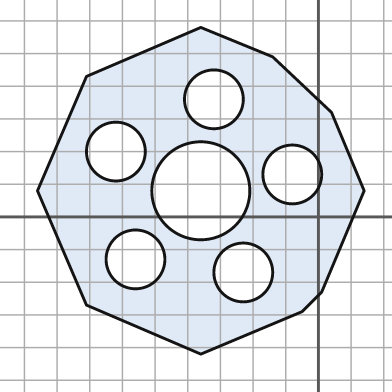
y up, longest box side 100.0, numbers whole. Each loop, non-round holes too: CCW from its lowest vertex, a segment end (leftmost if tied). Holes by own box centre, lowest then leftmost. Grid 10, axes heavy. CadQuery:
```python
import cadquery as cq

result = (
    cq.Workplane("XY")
    .moveTo(-36.0, -42.0)
    .lineTo(-5.0, -29.0)
    .lineTo(1.0, -23.0)
    .lineTo(14.0, 8.0)
    .lineTo(4.0, 32.0)
    .lineTo(-14.0, 49.0)
    .lineTo(-36.0, 58.0)
    .lineTo(-71.0, 43.0)
    .lineTo(-86.0, 8.0)
    .lineTo(-71.0, -27.0)
    .close()
    .moveTo(-23.0, -17.0)
    .circle(9.0)
    .moveTo(-56.0, -13.0)
    .circle(9.0)
    .moveTo(-36.0, 8.0)
    .circle(15.0)
    .moveTo(-8.0, 13.0)
    .circle(9.0)
    .moveTo(-62.0, 20.0)
    .circle(9.0)
    .moveTo(-32.0, 36.0)
    .circle(9.0)
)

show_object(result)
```